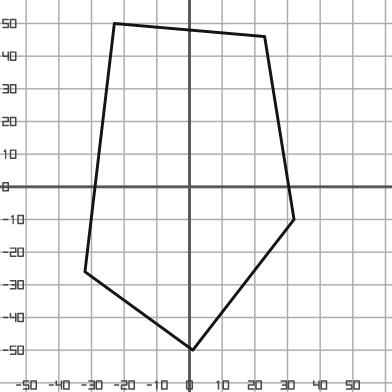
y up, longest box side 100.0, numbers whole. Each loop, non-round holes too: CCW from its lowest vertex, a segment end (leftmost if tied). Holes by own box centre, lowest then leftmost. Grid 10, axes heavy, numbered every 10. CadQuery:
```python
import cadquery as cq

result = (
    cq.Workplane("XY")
    .moveTo(1.0, -50.0)
    .lineTo(32.0, -10.0)
    .lineTo(23.0, 46.0)
    .lineTo(-23.0, 50.0)
    .lineTo(-32.0, -26.0)
    .close()
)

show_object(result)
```